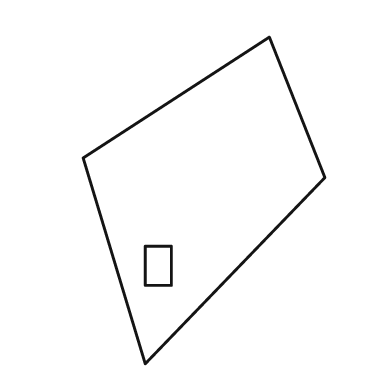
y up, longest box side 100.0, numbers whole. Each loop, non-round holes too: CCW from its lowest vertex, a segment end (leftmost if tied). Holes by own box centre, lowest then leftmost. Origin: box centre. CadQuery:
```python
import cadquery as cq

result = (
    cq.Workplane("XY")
    .moveTo(-18.0, -50.0)
    .lineTo(37.0, 7.0)
    .lineTo(20.0, 50.0)
    .lineTo(-37.0, 13.0)
    .close()
    .moveTo(-18.0, -26.0)
    .lineTo(-10.0, -26.0)
    .lineTo(-10.0, -14.0)
    .lineTo(-18.0, -14.0)
    .close()
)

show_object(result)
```